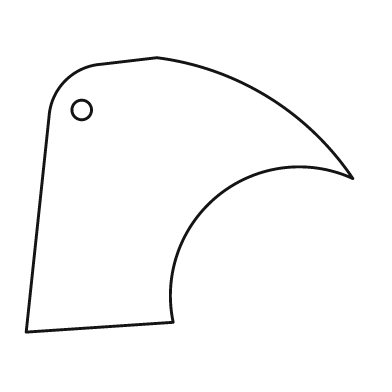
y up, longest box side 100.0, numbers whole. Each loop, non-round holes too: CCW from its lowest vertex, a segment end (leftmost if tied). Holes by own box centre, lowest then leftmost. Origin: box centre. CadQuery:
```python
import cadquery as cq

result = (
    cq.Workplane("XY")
    .moveTo(-50.0, -42.0)
    .lineTo(-5.0, -39.0)
    .threePointArc((9.0, 0.0), (50.0, 5.0))
    .threePointArc((24.0, 30.0), (-10.0, 42.0))
    .lineTo(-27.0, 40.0)
    .threePointArc((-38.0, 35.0), (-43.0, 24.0))
    .close()
    .moveTo(-33.0, 26.0)
    .circle(3.0)
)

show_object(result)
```